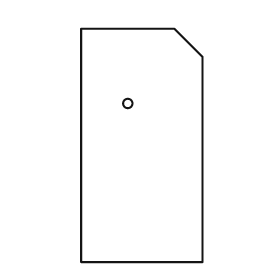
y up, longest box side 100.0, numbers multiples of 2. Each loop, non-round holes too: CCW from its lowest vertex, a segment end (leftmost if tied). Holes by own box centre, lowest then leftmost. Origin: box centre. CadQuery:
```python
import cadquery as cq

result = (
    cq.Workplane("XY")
    .moveTo(-26.0, -50.0)
    .lineTo(26.0, -50.0)
    .lineTo(26.0, 38.0)
    .lineTo(14.0, 50.0)
    .lineTo(-26.0, 50.0)
    .close()
    .moveTo(-6.0, 18.0)
    .circle(2.0)
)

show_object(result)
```